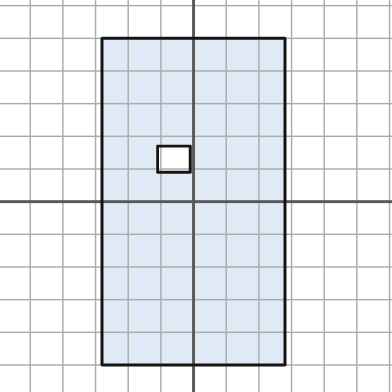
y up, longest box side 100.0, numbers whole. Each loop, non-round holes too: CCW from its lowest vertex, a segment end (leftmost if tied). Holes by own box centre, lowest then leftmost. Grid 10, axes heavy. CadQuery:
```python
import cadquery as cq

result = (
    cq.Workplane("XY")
    .moveTo(-28.0, -50.0)
    .lineTo(28.0, -50.0)
    .lineTo(28.0, 50.0)
    .lineTo(-28.0, 50.0)
    .close()
    .moveTo(-11.0, 9.0)
    .lineTo(-1.0, 9.0)
    .lineTo(-1.0, 17.0)
    .lineTo(-11.0, 17.0)
    .close()
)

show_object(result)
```